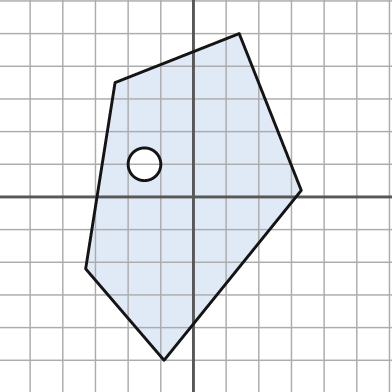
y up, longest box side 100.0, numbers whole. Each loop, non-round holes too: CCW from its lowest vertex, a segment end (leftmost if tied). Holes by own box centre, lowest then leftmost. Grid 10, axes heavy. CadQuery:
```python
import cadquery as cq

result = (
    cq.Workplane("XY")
    .moveTo(-9.0, -50.0)
    .lineTo(33.0, 2.0)
    .lineTo(14.0, 50.0)
    .lineTo(-24.0, 35.0)
    .lineTo(-33.0, -22.0)
    .close()
    .moveTo(-15.0, 10.0)
    .circle(5.0)
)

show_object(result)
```